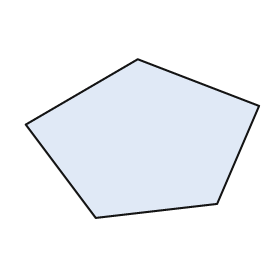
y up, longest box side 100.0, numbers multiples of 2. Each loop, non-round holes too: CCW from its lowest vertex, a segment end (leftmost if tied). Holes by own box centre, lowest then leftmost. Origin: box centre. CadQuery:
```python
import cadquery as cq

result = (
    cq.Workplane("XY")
    .moveTo(-20.0, -34.0)
    .lineTo(32.0, -28.0)
    .lineTo(50.0, 14.0)
    .lineTo(-2.0, 34.0)
    .lineTo(-50.0, 6.0)
    .close()
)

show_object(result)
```